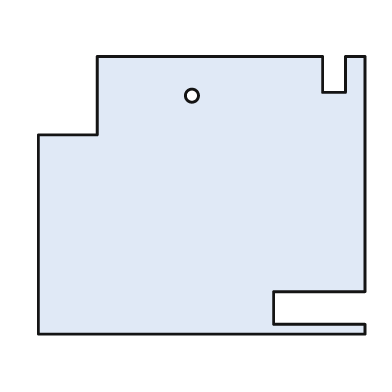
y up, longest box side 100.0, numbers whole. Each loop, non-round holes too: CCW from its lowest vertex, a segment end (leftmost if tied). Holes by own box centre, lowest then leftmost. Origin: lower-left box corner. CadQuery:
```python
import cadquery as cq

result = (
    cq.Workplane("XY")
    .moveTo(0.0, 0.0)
    .lineTo(100.0, 0.0)
    .lineTo(100.0, 3.0)
    .lineTo(72.0, 3.0)
    .lineTo(72.0, 13.0)
    .lineTo(100.0, 13.0)
    .lineTo(100.0, 85.0)
    .lineTo(94.0, 85.0)
    .lineTo(94.0, 74.0)
    .lineTo(87.0, 74.0)
    .lineTo(87.0, 85.0)
    .lineTo(18.0, 85.0)
    .lineTo(18.0, 61.0)
    .lineTo(0.0, 61.0)
    .close()
    .moveTo(47.0, 73.0)
    .circle(2.0)
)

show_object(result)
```